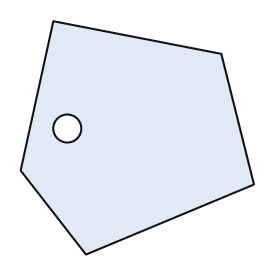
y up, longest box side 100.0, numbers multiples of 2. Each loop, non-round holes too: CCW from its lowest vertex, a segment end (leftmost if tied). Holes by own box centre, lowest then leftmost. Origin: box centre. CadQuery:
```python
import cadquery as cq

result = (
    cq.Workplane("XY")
    .moveTo(-22.0, -50.0)
    .lineTo(50.0, -20.0)
    .lineTo(36.0, 36.0)
    .lineTo(-36.0, 50.0)
    .lineTo(-50.0, -14.0)
    .close()
    .moveTo(-30.0, 4.0)
    .circle(6.0)
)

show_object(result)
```